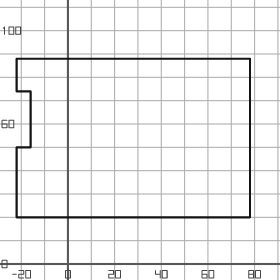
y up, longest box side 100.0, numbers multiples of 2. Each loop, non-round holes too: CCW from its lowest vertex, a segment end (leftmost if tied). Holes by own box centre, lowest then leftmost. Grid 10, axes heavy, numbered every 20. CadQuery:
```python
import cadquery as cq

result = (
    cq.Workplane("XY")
    .moveTo(-22.0, 20.0)
    .lineTo(78.0, 20.0)
    .lineTo(78.0, 88.0)
    .lineTo(-22.0, 88.0)
    .lineTo(-22.0, 74.0)
    .lineTo(-16.0, 74.0)
    .lineTo(-16.0, 50.0)
    .lineTo(-22.0, 50.0)
    .close()
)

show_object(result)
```